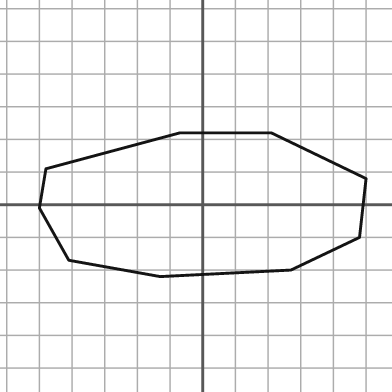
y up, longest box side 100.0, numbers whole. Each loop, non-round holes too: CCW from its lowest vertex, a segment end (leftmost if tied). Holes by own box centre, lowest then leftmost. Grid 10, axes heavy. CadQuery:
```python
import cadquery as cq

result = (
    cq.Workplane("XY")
    .moveTo(-13.0, -22.0)
    .lineTo(27.0, -20.0)
    .lineTo(48.0, -10.0)
    .lineTo(50.0, 8.0)
    .lineTo(21.0, 22.0)
    .lineTo(-7.0, 22.0)
    .lineTo(-48.0, 11.0)
    .lineTo(-50.0, -1.0)
    .lineTo(-41.0, -17.0)
    .close()
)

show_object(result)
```